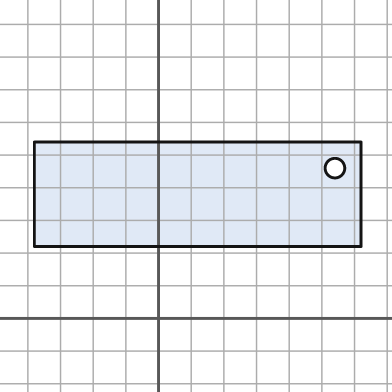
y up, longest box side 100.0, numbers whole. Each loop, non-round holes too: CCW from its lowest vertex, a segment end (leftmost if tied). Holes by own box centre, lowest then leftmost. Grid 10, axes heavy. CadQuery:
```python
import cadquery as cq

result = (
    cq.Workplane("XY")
    .moveTo(-38.0, 22.0)
    .lineTo(62.0, 22.0)
    .lineTo(62.0, 54.0)
    .lineTo(-38.0, 54.0)
    .close()
    .moveTo(54.0, 46.0)
    .circle(3.0)
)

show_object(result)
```